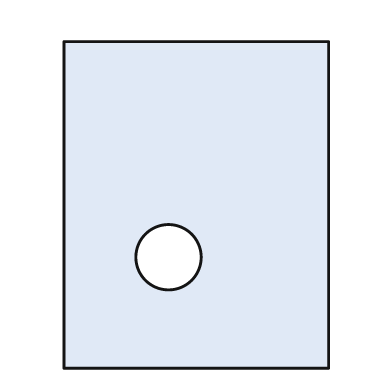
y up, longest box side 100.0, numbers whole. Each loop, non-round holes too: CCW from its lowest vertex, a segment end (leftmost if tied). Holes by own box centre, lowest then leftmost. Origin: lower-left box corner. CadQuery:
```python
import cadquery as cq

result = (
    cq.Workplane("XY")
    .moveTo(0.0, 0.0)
    .lineTo(81.0, 0.0)
    .lineTo(81.0, 100.0)
    .lineTo(0.0, 100.0)
    .close()
    .moveTo(32.0, 34.0)
    .circle(10.0)
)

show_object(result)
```